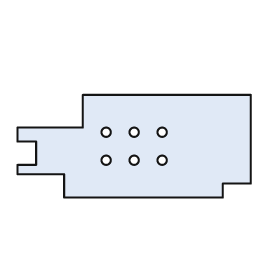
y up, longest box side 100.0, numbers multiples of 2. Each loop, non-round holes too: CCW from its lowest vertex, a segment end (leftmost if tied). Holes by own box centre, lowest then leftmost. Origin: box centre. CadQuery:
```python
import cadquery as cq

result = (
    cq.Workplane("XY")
    .moveTo(-30.0, -22.0)
    .lineTo(38.0, -22.0)
    .lineTo(38.0, -16.0)
    .lineTo(50.0, -16.0)
    .lineTo(50.0, 22.0)
    .lineTo(-22.0, 22.0)
    .lineTo(-22.0, 8.0)
    .lineTo(-50.0, 8.0)
    .lineTo(-50.0, 2.0)
    .lineTo(-42.0, 2.0)
    .lineTo(-42.0, -8.0)
    .lineTo(-50.0, -8.0)
    .lineTo(-50.0, -12.0)
    .lineTo(-30.0, -12.0)
    .close()
    .moveTo(-12.0, -6.0)
    .circle(2.0)
    .moveTo(0.0, -6.0)
    .circle(2.0)
    .moveTo(12.0, -6.0)
    .circle(2.0)
    .moveTo(-12.0, 6.0)
    .circle(2.0)
    .moveTo(0.0, 6.0)
    .circle(2.0)
    .moveTo(12.0, 6.0)
    .circle(2.0)
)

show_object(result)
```